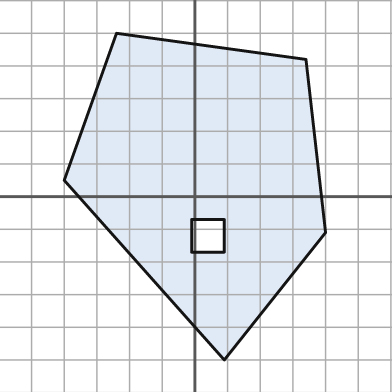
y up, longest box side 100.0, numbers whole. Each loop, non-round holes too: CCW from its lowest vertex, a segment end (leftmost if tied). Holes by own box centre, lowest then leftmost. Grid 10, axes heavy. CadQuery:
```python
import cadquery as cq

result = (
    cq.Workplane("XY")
    .moveTo(9.0, -50.0)
    .lineTo(40.0, -11.0)
    .lineTo(34.0, 42.0)
    .lineTo(-24.0, 50.0)
    .lineTo(-40.0, 5.0)
    .close()
    .moveTo(-1.0, -17.0)
    .lineTo(9.0, -17.0)
    .lineTo(9.0, -7.0)
    .lineTo(-1.0, -7.0)
    .close()
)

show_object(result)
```